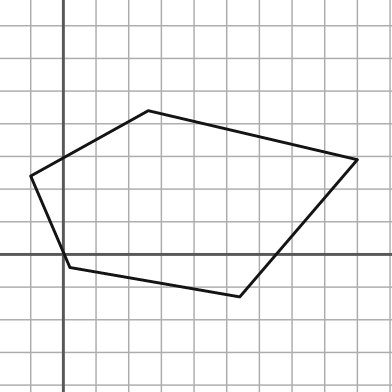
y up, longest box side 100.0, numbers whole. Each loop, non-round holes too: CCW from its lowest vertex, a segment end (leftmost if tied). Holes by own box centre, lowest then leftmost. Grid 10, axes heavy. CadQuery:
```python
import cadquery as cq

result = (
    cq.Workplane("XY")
    .moveTo(54.0, -13.0)
    .lineTo(90.0, 29.0)
    .lineTo(26.0, 44.0)
    .lineTo(-10.0, 24.0)
    .lineTo(2.0, -4.0)
    .close()
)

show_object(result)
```